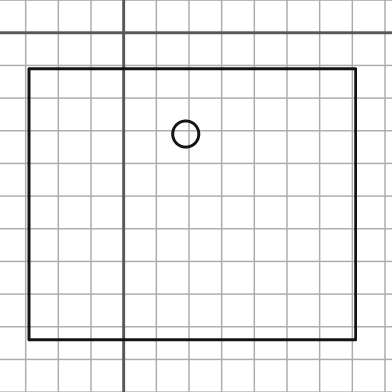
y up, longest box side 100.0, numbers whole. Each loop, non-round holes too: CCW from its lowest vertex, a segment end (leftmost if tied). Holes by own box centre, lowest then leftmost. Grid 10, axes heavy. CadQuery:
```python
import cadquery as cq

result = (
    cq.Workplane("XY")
    .moveTo(-29.0, -94.0)
    .lineTo(71.0, -94.0)
    .lineTo(71.0, -11.0)
    .lineTo(-29.0, -11.0)
    .close()
    .moveTo(19.0, -31.0)
    .circle(4.0)
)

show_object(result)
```